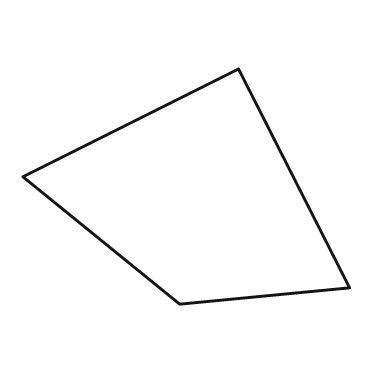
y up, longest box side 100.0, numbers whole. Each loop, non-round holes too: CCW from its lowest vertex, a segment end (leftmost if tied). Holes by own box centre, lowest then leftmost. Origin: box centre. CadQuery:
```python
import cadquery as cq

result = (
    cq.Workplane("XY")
    .moveTo(-2.0, -36.0)
    .lineTo(50.0, -31.0)
    .lineTo(16.0, 36.0)
    .lineTo(-50.0, 3.0)
    .close()
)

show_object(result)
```